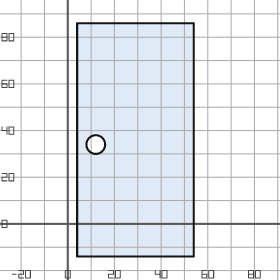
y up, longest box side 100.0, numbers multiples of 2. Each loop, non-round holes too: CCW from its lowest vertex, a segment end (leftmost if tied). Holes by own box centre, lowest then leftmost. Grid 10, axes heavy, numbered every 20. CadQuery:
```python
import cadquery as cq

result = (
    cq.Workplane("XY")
    .moveTo(4.0, -14.0)
    .lineTo(54.0, -14.0)
    .lineTo(54.0, 86.0)
    .lineTo(4.0, 86.0)
    .close()
    .moveTo(12.0, 34.0)
    .circle(4.0)
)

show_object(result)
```